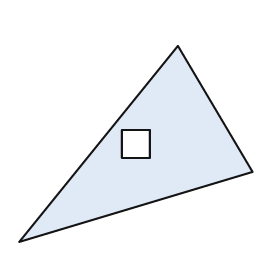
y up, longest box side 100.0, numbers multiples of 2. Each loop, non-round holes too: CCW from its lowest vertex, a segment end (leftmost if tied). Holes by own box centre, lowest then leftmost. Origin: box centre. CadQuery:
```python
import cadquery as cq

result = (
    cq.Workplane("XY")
    .moveTo(-50.0, -42.0)
    .lineTo(50.0, -12.0)
    .lineTo(18.0, 42.0)
    .close()
    .moveTo(-6.0, -6.0)
    .lineTo(6.0, -6.0)
    .lineTo(6.0, 6.0)
    .lineTo(-6.0, 6.0)
    .close()
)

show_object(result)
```